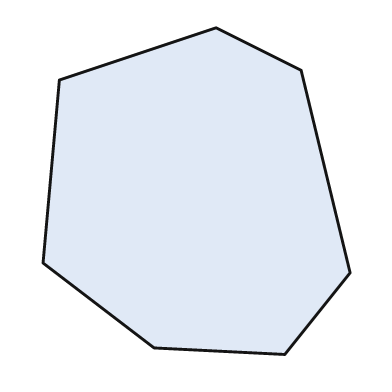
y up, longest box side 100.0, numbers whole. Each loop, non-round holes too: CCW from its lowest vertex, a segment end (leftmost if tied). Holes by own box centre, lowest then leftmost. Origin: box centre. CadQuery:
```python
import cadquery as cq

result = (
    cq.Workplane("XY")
    .moveTo(27.0, -50.0)
    .lineTo(47.0, -25.0)
    .lineTo(32.0, 37.0)
    .lineTo(6.0, 50.0)
    .lineTo(-42.0, 34.0)
    .lineTo(-47.0, -22.0)
    .lineTo(-13.0, -48.0)
    .close()
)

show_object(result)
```